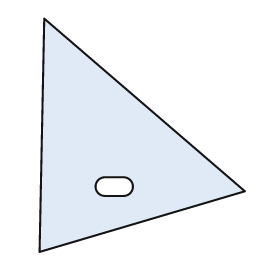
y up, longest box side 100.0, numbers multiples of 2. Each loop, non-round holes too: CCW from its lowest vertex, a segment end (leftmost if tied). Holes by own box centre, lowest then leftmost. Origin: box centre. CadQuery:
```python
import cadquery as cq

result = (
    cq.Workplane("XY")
    .moveTo(-44.0, -50.0)
    .lineTo(44.0, -24.0)
    .lineTo(-42.0, 50.0)
    .close()
    .moveTo(-16.0, -26.0)
    .lineTo(-8.0, -26.0)
    .threePointArc((-4.0, -22.0), (-8.0, -18.0))
    .lineTo(-16.0, -18.0)
    .threePointArc((-20.0, -22.0), (-16.0, -26.0))
    .close()
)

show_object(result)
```